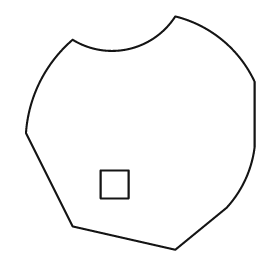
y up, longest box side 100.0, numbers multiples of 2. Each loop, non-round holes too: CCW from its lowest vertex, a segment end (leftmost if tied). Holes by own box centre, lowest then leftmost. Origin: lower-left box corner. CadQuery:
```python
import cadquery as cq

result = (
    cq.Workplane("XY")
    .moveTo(64.0, 0.0)
    .lineTo(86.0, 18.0)
    .threePointArc((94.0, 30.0), (98.0, 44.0))
    .lineTo(98.0, 72.0)
    .threePointArc((84.0, 90.0), (64.0, 100.0))
    .threePointArc((44.0, 86.0), (20.0, 90.0))
    .threePointArc((6.0, 72.0), (0.0, 50.0))
    .lineTo(20.0, 10.0)
    .close()
    .moveTo(32.0, 22.0)
    .lineTo(44.0, 22.0)
    .lineTo(44.0, 34.0)
    .lineTo(32.0, 34.0)
    .close()
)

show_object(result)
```